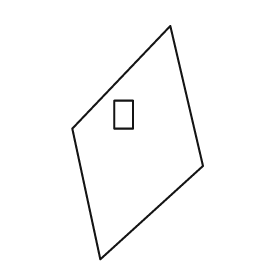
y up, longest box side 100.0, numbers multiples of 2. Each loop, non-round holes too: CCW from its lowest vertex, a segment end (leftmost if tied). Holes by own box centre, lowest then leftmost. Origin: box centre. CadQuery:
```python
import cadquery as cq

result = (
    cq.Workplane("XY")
    .moveTo(-16.0, -50.0)
    .lineTo(28.0, -10.0)
    .lineTo(14.0, 50.0)
    .lineTo(-28.0, 6.0)
    .close()
    .moveTo(-10.0, 6.0)
    .lineTo(-2.0, 6.0)
    .lineTo(-2.0, 18.0)
    .lineTo(-10.0, 18.0)
    .close()
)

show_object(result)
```